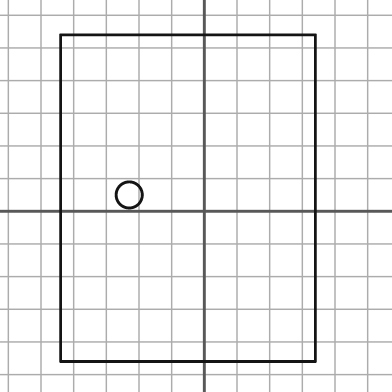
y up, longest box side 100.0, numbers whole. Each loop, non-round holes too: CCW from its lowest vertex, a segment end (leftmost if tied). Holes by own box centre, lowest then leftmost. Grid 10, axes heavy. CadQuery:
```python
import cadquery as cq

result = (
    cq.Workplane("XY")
    .moveTo(-44.0, -46.0)
    .lineTo(34.0, -46.0)
    .lineTo(34.0, 54.0)
    .lineTo(-44.0, 54.0)
    .close()
    .moveTo(-23.0, 5.0)
    .circle(4.0)
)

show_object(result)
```